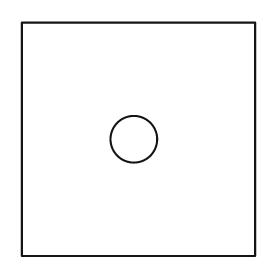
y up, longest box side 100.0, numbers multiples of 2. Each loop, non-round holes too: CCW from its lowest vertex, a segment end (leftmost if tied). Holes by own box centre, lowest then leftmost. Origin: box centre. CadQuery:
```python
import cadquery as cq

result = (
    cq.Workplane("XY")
    .moveTo(-50.0, -50.0)
    .lineTo(50.0, -50.0)
    .lineTo(50.0, 50.0)
    .lineTo(-50.0, 50.0)
    .close()
    .moveTo(-2.0, 0.0)
    .circle(10.0)
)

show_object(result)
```